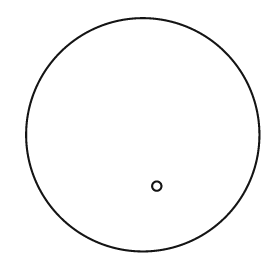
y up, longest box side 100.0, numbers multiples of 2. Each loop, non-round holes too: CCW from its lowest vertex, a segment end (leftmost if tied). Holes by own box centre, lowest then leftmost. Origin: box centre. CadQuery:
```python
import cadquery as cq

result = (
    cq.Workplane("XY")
    .moveTo(0.0, 0.0)
    .circle(50.0)
    .moveTo(6.0, -22.0)
    .circle(2.0)
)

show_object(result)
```